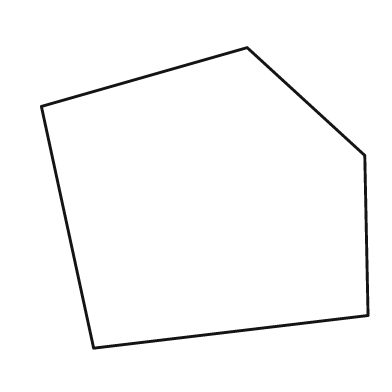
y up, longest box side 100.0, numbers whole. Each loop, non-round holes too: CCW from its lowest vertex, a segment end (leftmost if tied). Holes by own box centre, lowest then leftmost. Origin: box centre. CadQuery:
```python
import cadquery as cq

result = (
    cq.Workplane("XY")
    .moveTo(-34.0, -46.0)
    .lineTo(50.0, -36.0)
    .lineTo(49.0, 13.0)
    .lineTo(13.0, 46.0)
    .lineTo(-50.0, 28.0)
    .close()
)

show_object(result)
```